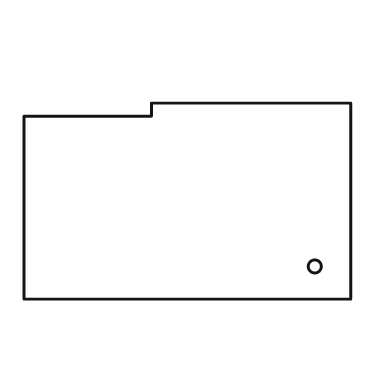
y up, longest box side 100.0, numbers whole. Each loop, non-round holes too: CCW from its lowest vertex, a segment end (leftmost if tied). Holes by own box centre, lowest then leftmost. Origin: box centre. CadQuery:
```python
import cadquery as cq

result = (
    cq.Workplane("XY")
    .moveTo(-50.0, -30.0)
    .lineTo(50.0, -30.0)
    .lineTo(50.0, 30.0)
    .lineTo(-11.0, 30.0)
    .lineTo(-11.0, 26.0)
    .lineTo(-50.0, 26.0)
    .close()
    .moveTo(39.0, -20.0)
    .circle(2.0)
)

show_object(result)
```